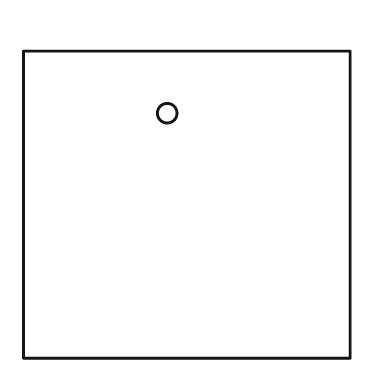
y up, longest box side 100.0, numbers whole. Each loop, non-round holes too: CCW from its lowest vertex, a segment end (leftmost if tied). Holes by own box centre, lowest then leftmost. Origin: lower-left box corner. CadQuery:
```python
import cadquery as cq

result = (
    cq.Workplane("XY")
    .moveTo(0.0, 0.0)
    .lineTo(100.0, 0.0)
    .lineTo(100.0, 94.0)
    .lineTo(0.0, 94.0)
    .close()
    .moveTo(44.0, 75.0)
    .circle(3.0)
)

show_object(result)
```